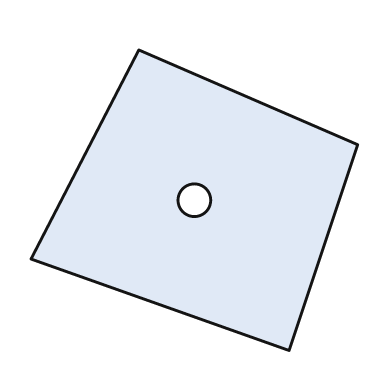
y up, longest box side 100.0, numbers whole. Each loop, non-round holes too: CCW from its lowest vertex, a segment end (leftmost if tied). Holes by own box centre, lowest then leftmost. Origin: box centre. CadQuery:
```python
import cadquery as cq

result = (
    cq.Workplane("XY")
    .moveTo(29.0, -46.0)
    .lineTo(50.0, 17.0)
    .lineTo(-17.0, 46.0)
    .lineTo(-50.0, -18.0)
    .close()
    .moveTo(0.0, 0.0)
    .circle(5.0)
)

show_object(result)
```